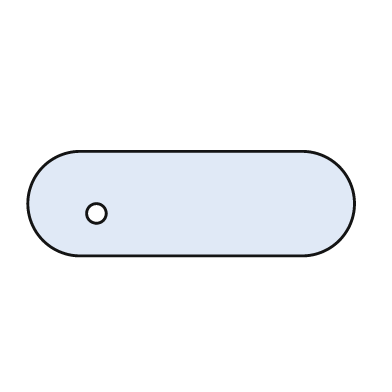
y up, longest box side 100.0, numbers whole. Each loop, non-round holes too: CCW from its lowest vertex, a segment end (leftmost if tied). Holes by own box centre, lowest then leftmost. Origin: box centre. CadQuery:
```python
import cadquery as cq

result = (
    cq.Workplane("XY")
    .moveTo(-34.0, -16.0)
    .lineTo(34.0, -16.0)
    .threePointArc((50.0, 0.0), (34.0, 16.0))
    .lineTo(-34.0, 16.0)
    .threePointArc((-50.0, 0.0), (-34.0, -16.0))
    .close()
    .moveTo(-29.0, -3.0)
    .circle(3.0)
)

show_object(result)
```